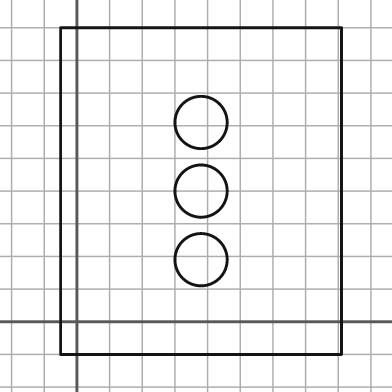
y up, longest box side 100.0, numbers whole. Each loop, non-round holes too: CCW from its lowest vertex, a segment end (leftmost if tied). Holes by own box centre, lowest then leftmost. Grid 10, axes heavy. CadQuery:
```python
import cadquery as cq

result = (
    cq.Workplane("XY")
    .moveTo(-5.0, -10.0)
    .lineTo(81.0, -10.0)
    .lineTo(81.0, 90.0)
    .lineTo(-5.0, 90.0)
    .close()
    .moveTo(38.0, 19.0)
    .circle(8.0)
    .moveTo(38.0, 40.0)
    .circle(8.0)
    .moveTo(38.0, 61.0)
    .circle(8.0)
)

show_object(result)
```